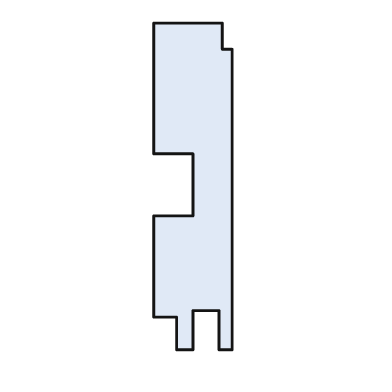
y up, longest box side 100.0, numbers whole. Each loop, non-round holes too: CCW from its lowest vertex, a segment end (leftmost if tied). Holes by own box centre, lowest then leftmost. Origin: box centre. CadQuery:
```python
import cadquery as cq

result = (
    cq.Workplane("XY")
    .moveTo(-5.0, -50.0)
    .lineTo(0.0, -50.0)
    .lineTo(0.0, -38.0)
    .lineTo(8.0, -38.0)
    .lineTo(8.0, -50.0)
    .lineTo(12.0, -50.0)
    .lineTo(12.0, 42.0)
    .lineTo(9.0, 42.0)
    .lineTo(9.0, 50.0)
    .lineTo(-12.0, 50.0)
    .lineTo(-12.0, 10.0)
    .lineTo(0.0, 10.0)
    .lineTo(0.0, -9.0)
    .lineTo(-12.0, -9.0)
    .lineTo(-12.0, -40.0)
    .lineTo(-5.0, -40.0)
    .close()
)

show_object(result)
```